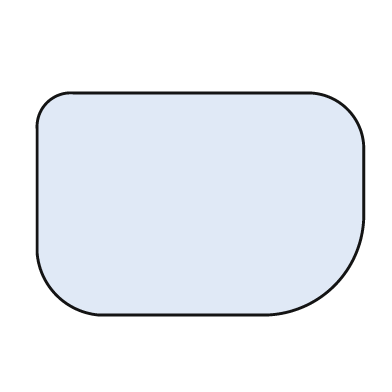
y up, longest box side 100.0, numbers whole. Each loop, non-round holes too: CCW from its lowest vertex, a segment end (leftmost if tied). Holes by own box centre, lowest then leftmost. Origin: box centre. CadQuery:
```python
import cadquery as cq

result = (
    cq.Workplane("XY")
    .moveTo(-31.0, -34.0)
    .lineTo(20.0, -34.0)
    .threePointArc((41.0, -25.0), (50.0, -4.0))
    .lineTo(50.0, 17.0)
    .threePointArc((45.0, 29.0), (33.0, 34.0))
    .lineTo(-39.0, 34.0)
    .threePointArc((-47.0, 31.0), (-50.0, 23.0))
    .lineTo(-50.0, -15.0)
    .threePointArc((-44.0, -28.0), (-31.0, -34.0))
    .close()
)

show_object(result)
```